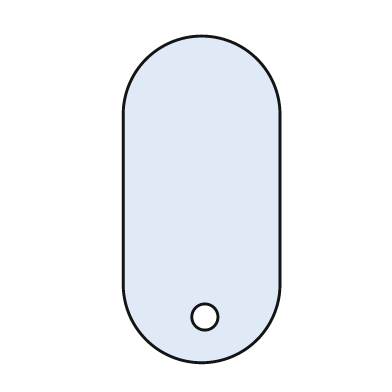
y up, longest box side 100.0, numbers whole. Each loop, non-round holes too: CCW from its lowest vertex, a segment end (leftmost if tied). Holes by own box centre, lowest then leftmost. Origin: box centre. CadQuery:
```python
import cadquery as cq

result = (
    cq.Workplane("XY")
    .moveTo(-24.0, -26.0)
    .threePointArc((0.0, -50.0), (24.0, -26.0))
    .lineTo(24.0, 26.0)
    .threePointArc((0.0, 50.0), (-24.0, 26.0))
    .close()
    .moveTo(1.0, -36.0)
    .circle(4.0)
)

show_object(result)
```